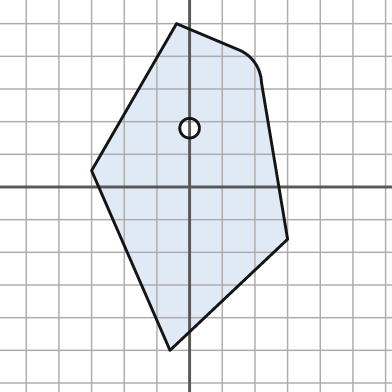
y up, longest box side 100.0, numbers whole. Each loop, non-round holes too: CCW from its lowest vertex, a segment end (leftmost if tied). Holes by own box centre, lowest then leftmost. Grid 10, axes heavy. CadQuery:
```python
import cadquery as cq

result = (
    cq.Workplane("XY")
    .moveTo(-6.0, -50.0)
    .lineTo(30.0, -16.0)
    .lineTo(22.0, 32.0)
    .threePointArc((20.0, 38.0), (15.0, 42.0))
    .lineTo(-4.0, 50.0)
    .lineTo(-30.0, 5.0)
    .close()
    .moveTo(0.0, 18.0)
    .circle(3.0)
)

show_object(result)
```